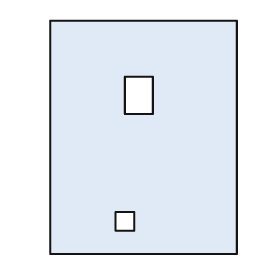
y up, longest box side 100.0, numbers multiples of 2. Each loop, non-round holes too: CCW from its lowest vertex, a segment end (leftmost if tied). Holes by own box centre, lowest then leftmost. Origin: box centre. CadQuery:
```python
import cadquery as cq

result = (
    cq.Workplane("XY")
    .moveTo(-40.0, -50.0)
    .lineTo(40.0, -50.0)
    .lineTo(40.0, 50.0)
    .lineTo(-40.0, 50.0)
    .close()
    .moveTo(-12.0, -40.0)
    .lineTo(-4.0, -40.0)
    .lineTo(-4.0, -32.0)
    .lineTo(-12.0, -32.0)
    .close()
    .moveTo(-8.0, 10.0)
    .lineTo(4.0, 10.0)
    .lineTo(4.0, 26.0)
    .lineTo(-8.0, 26.0)
    .close()
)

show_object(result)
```